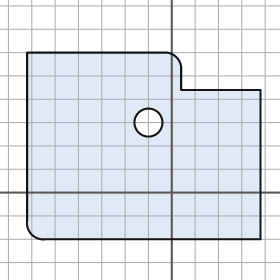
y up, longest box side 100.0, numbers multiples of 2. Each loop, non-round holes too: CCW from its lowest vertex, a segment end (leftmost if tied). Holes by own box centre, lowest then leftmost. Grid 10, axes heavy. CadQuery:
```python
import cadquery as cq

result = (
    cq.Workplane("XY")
    .moveTo(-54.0, -20.0)
    .lineTo(38.0, -20.0)
    .lineTo(38.0, 44.0)
    .lineTo(4.0, 44.0)
    .lineTo(4.0, 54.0)
    .threePointArc((2.0, 58.0), (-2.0, 60.0))
    .lineTo(-62.0, 60.0)
    .lineTo(-62.0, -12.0)
    .threePointArc((-60.0, -18.0), (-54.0, -20.0))
    .close()
    .moveTo(-10.0, 30.0)
    .circle(6.0)
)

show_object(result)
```